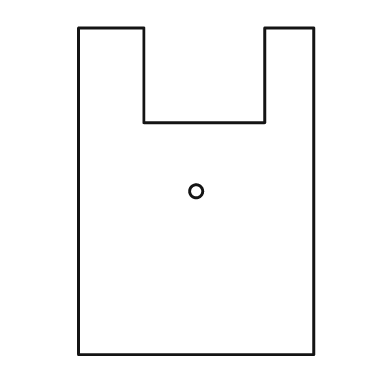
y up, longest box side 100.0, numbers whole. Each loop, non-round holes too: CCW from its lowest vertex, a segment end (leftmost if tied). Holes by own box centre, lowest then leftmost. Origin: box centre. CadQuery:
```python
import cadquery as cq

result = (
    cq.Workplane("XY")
    .moveTo(-36.0, -50.0)
    .lineTo(36.0, -50.0)
    .lineTo(36.0, 50.0)
    .lineTo(21.0, 50.0)
    .lineTo(21.0, 21.0)
    .lineTo(-16.0, 21.0)
    .lineTo(-16.0, 50.0)
    .lineTo(-36.0, 50.0)
    .close()
    .moveTo(0.0, 0.0)
    .circle(2.0)
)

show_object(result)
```